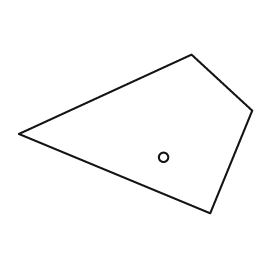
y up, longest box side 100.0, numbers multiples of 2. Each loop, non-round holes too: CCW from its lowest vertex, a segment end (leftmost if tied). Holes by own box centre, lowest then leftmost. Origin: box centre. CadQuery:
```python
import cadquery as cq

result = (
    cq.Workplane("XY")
    .moveTo(32.0, -34.0)
    .lineTo(50.0, 10.0)
    .lineTo(24.0, 34.0)
    .lineTo(-50.0, 0.0)
    .close()
    .moveTo(12.0, -10.0)
    .circle(2.0)
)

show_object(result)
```